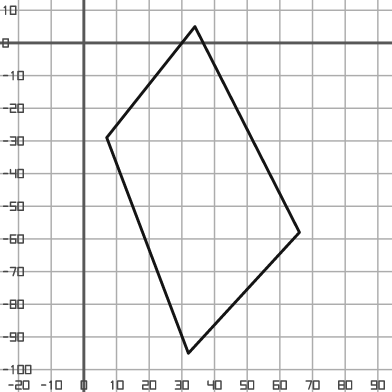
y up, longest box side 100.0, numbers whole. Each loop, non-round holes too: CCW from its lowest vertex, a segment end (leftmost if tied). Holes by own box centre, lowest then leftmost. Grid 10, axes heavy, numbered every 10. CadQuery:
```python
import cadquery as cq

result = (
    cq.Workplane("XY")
    .moveTo(32.0, -95.0)
    .lineTo(66.0, -58.0)
    .lineTo(34.0, 5.0)
    .lineTo(7.0, -29.0)
    .close()
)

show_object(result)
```